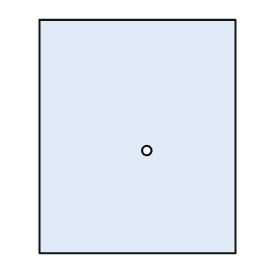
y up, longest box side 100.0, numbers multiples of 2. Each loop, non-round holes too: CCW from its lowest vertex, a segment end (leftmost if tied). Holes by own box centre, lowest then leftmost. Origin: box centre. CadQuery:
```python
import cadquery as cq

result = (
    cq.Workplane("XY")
    .moveTo(-42.0, -50.0)
    .lineTo(42.0, -50.0)
    .lineTo(42.0, 50.0)
    .lineTo(-42.0, 50.0)
    .close()
    .moveTo(4.0, -6.0)
    .circle(2.0)
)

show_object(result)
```